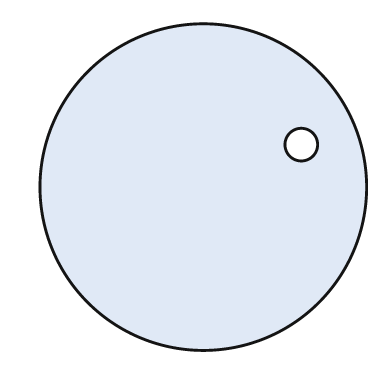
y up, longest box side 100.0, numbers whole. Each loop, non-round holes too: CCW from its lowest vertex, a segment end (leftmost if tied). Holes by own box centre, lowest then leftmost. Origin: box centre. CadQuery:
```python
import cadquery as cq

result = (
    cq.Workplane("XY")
    .moveTo(0.0, 0.0)
    .circle(50.0)
    .moveTo(30.0, 13.0)
    .circle(5.0)
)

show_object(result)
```